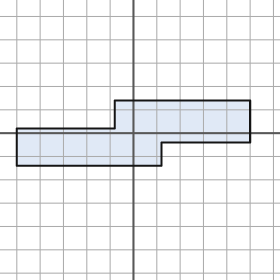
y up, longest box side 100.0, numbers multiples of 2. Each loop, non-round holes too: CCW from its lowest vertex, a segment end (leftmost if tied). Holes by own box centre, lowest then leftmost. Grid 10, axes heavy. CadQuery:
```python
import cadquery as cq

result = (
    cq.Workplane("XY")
    .moveTo(-50.0, -14.0)
    .lineTo(12.0, -14.0)
    .lineTo(12.0, -4.0)
    .lineTo(50.0, -4.0)
    .lineTo(50.0, 14.0)
    .lineTo(-8.0, 14.0)
    .lineTo(-8.0, 2.0)
    .lineTo(-50.0, 2.0)
    .close()
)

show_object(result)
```